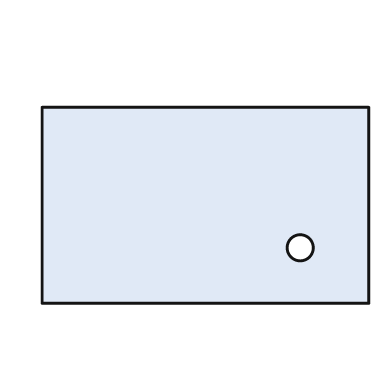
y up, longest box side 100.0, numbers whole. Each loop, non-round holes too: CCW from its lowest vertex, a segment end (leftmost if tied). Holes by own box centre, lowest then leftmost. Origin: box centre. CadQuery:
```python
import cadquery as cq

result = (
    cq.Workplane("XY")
    .moveTo(-50.0, -30.0)
    .lineTo(50.0, -30.0)
    .lineTo(50.0, 30.0)
    .lineTo(-50.0, 30.0)
    .close()
    .moveTo(29.0, -13.0)
    .circle(4.0)
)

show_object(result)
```